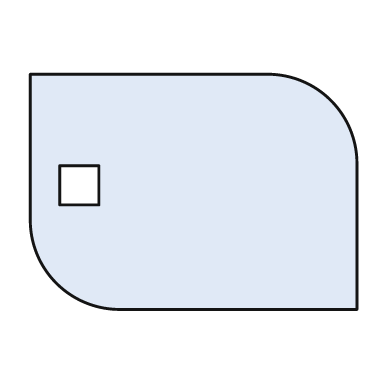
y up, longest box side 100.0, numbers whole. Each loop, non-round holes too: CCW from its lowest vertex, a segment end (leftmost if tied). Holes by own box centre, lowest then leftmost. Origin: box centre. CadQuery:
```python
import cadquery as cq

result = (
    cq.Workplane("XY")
    .moveTo(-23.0, -36.0)
    .lineTo(50.0, -36.0)
    .lineTo(50.0, 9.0)
    .threePointArc((42.0, 28.0), (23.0, 36.0))
    .lineTo(-50.0, 36.0)
    .lineTo(-50.0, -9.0)
    .threePointArc((-42.0, -28.0), (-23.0, -36.0))
    .close()
    .moveTo(-41.0, -4.0)
    .lineTo(-29.0, -4.0)
    .lineTo(-29.0, 8.0)
    .lineTo(-41.0, 8.0)
    .close()
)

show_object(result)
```